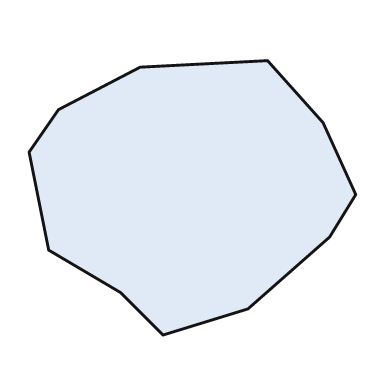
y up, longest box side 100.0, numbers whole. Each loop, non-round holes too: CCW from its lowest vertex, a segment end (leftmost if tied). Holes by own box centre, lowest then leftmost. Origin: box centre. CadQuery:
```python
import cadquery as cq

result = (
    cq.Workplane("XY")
    .moveTo(-9.0, -42.0)
    .lineTo(17.0, -34.0)
    .lineTo(42.0, -12.0)
    .lineTo(50.0, 1.0)
    .lineTo(40.0, 23.0)
    .lineTo(23.0, 42.0)
    .lineTo(-16.0, 40.0)
    .lineTo(-41.0, 27.0)
    .lineTo(-50.0, 14.0)
    .lineTo(-44.0, -16.0)
    .lineTo(-22.0, -29.0)
    .close()
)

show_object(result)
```